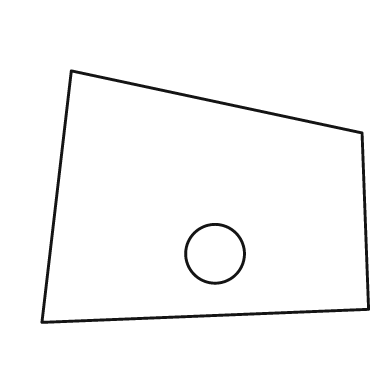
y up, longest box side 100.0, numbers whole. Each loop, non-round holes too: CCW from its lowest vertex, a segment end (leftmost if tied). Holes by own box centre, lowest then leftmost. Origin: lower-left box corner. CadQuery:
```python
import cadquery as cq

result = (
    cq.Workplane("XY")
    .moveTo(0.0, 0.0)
    .lineTo(100.0, 4.0)
    .lineTo(98.0, 58.0)
    .lineTo(9.0, 77.0)
    .close()
    .moveTo(53.0, 21.0)
    .circle(9.0)
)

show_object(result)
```